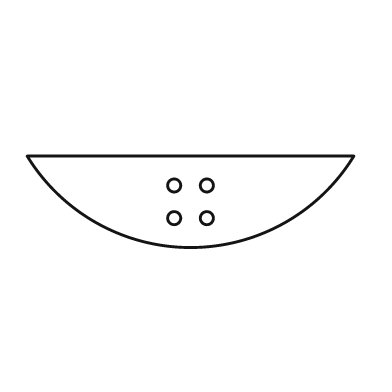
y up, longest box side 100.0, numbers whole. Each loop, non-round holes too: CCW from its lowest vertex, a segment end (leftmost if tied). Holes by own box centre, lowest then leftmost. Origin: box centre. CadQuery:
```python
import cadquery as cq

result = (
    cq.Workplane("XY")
    .moveTo(-50.0, 14.0)
    .threePointArc((0.0, -14.0), (50.0, 14.0))
    .close()
    .moveTo(-5.0, -5.0)
    .circle(2.0)
    .moveTo(5.0, -5.0)
    .circle(2.0)
    .moveTo(-5.0, 5.0)
    .circle(2.0)
    .moveTo(5.0, 5.0)
    .circle(2.0)
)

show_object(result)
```